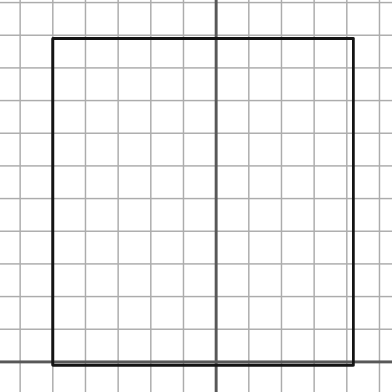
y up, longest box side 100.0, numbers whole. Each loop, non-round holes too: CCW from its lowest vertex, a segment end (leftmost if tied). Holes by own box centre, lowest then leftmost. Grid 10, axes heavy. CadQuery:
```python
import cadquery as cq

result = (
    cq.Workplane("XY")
    .moveTo(-50.0, -1.0)
    .lineTo(42.0, -1.0)
    .lineTo(42.0, 99.0)
    .lineTo(-50.0, 99.0)
    .close()
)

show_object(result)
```